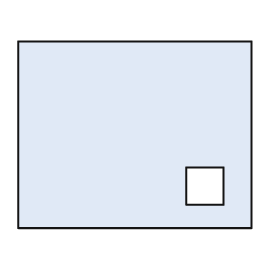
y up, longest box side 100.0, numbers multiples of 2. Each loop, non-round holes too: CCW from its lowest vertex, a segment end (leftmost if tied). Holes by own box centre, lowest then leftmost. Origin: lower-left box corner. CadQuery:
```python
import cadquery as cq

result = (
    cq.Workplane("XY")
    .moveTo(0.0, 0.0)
    .lineTo(100.0, 0.0)
    .lineTo(100.0, 80.0)
    .lineTo(0.0, 80.0)
    .close()
    .moveTo(72.0, 10.0)
    .lineTo(88.0, 10.0)
    .lineTo(88.0, 26.0)
    .lineTo(72.0, 26.0)
    .close()
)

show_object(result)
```